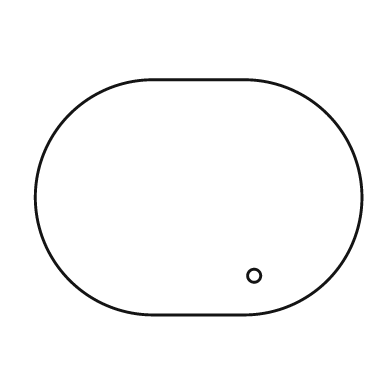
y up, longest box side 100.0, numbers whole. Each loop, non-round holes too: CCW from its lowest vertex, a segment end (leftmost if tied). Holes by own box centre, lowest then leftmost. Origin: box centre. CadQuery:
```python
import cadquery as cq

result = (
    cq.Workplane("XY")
    .moveTo(-14.0, -36.0)
    .lineTo(14.0, -36.0)
    .threePointArc((50.0, 0.0), (14.0, 36.0))
    .lineTo(-14.0, 36.0)
    .threePointArc((-50.0, 0.0), (-14.0, -36.0))
    .close()
    .moveTo(17.0, -24.0)
    .circle(2.0)
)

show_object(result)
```